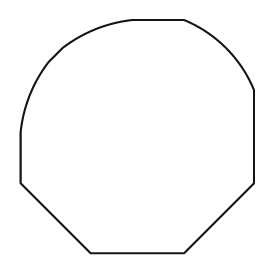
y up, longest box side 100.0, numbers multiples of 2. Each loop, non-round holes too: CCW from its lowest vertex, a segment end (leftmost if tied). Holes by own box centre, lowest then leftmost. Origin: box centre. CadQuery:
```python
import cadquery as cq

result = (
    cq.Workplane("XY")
    .moveTo(-20.0, -50.0)
    .lineTo(20.0, -50.0)
    .lineTo(50.0, -20.0)
    .lineTo(50.0, 20.0)
    .threePointArc((38.0, 38.0), (20.0, 50.0))
    .lineTo(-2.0, 50.0)
    .threePointArc((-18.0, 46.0), (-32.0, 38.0))
    .lineTo(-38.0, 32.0)
    .threePointArc((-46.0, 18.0), (-50.0, 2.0))
    .lineTo(-50.0, -20.0)
    .close()
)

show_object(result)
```